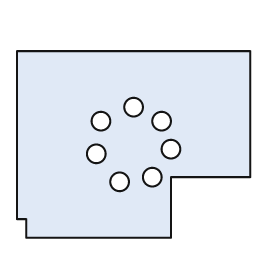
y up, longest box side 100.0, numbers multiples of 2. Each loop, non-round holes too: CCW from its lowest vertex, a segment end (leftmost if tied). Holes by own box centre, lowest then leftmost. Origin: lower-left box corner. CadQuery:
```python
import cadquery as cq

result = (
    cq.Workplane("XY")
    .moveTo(4.0, 0.0)
    .lineTo(66.0, 0.0)
    .lineTo(66.0, 26.0)
    .lineTo(100.0, 26.0)
    .lineTo(100.0, 80.0)
    .lineTo(0.0, 80.0)
    .lineTo(0.0, 8.0)
    .lineTo(4.0, 8.0)
    .close()
    .moveTo(44.0, 24.0)
    .circle(4.0)
    .moveTo(58.0, 26.0)
    .circle(4.0)
    .moveTo(34.0, 36.0)
    .circle(4.0)
    .moveTo(66.0, 38.0)
    .circle(4.0)
    .moveTo(36.0, 50.0)
    .circle(4.0)
    .moveTo(62.0, 50.0)
    .circle(4.0)
    .moveTo(50.0, 56.0)
    .circle(4.0)
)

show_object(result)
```